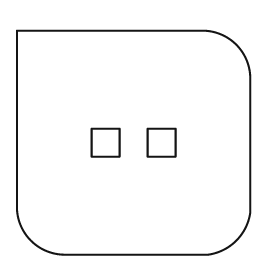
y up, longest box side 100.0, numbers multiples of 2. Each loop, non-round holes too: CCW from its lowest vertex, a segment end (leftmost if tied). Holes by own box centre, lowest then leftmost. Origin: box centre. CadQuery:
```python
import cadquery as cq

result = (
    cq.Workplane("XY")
    .moveTo(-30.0, -48.0)
    .lineTo(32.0, -48.0)
    .threePointArc((44.0, -42.0), (50.0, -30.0))
    .lineTo(50.0, 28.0)
    .threePointArc((44.0, 42.0), (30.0, 48.0))
    .lineTo(-50.0, 48.0)
    .lineTo(-50.0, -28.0)
    .threePointArc((-44.0, -42.0), (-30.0, -48.0))
    .close()
    .moveTo(-18.0, -6.0)
    .lineTo(-6.0, -6.0)
    .lineTo(-6.0, 6.0)
    .lineTo(-18.0, 6.0)
    .close()
    .moveTo(6.0, -6.0)
    .lineTo(18.0, -6.0)
    .lineTo(18.0, 6.0)
    .lineTo(6.0, 6.0)
    .close()
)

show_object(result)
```